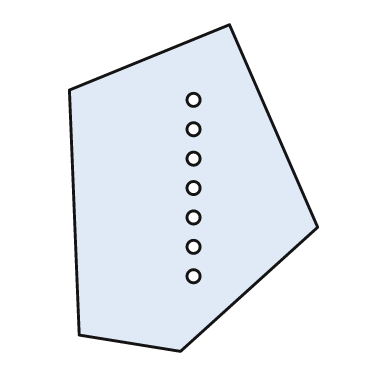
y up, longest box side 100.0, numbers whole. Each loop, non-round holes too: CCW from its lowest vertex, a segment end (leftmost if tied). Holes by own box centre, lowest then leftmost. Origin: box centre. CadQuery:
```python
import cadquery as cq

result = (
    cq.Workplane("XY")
    .moveTo(-4.0, -50.0)
    .lineTo(38.0, -12.0)
    .lineTo(11.0, 50.0)
    .lineTo(-38.0, 30.0)
    .lineTo(-35.0, -45.0)
    .close()
    .moveTo(0.0, -27.0)
    .circle(2.0)
    .moveTo(0.0, -18.0)
    .circle(2.0)
    .moveTo(0.0, -9.0)
    .circle(2.0)
    .moveTo(0.0, 0.0)
    .circle(2.0)
    .moveTo(0.0, 9.0)
    .circle(2.0)
    .moveTo(0.0, 18.0)
    .circle(2.0)
    .moveTo(0.0, 27.0)
    .circle(2.0)
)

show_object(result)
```